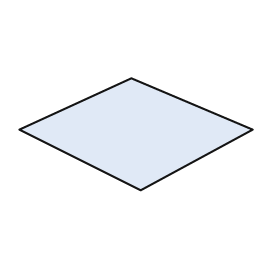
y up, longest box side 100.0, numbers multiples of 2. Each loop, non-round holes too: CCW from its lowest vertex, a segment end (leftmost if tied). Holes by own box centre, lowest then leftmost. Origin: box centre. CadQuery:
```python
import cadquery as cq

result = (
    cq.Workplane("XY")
    .moveTo(2.0, -24.0)
    .lineTo(50.0, 2.0)
    .lineTo(-2.0, 24.0)
    .lineTo(-50.0, 2.0)
    .close()
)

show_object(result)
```